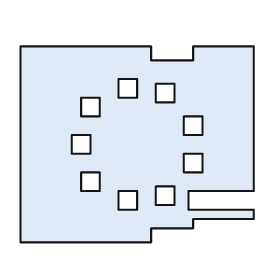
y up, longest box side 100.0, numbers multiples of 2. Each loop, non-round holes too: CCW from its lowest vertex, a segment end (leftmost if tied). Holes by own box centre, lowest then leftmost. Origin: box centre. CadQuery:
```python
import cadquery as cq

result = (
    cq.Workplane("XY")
    .moveTo(-50.0, -42.0)
    .lineTo(6.0, -42.0)
    .lineTo(6.0, -36.0)
    .lineTo(24.0, -36.0)
    .lineTo(24.0, -32.0)
    .lineTo(50.0, -32.0)
    .lineTo(50.0, -28.0)
    .lineTo(22.0, -28.0)
    .lineTo(22.0, -20.0)
    .lineTo(50.0, -20.0)
    .lineTo(50.0, 42.0)
    .lineTo(24.0, 42.0)
    .lineTo(24.0, 36.0)
    .lineTo(6.0, 36.0)
    .lineTo(6.0, 42.0)
    .lineTo(-50.0, 42.0)
    .close()
    .moveTo(-8.0, -28.0)
    .lineTo(0.0, -28.0)
    .lineTo(0.0, -20.0)
    .lineTo(-8.0, -20.0)
    .close()
    .moveTo(8.0, -26.0)
    .lineTo(16.0, -26.0)
    .lineTo(16.0, -18.0)
    .lineTo(8.0, -18.0)
    .close()
    .moveTo(-24.0, -20.0)
    .lineTo(-16.0, -20.0)
    .lineTo(-16.0, -12.0)
    .lineTo(-24.0, -12.0)
    .close()
    .moveTo(20.0, -12.0)
    .lineTo(28.0, -12.0)
    .lineTo(28.0, -4.0)
    .lineTo(20.0, -4.0)
    .close()
    .moveTo(-28.0, -4.0)
    .lineTo(-20.0, -4.0)
    .lineTo(-20.0, 4.0)
    .lineTo(-28.0, 4.0)
    .close()
    .moveTo(20.0, 4.0)
    .lineTo(28.0, 4.0)
    .lineTo(28.0, 12.0)
    .lineTo(20.0, 12.0)
    .close()
    .moveTo(-24.0, 12.0)
    .lineTo(-16.0, 12.0)
    .lineTo(-16.0, 20.0)
    .lineTo(-24.0, 20.0)
    .close()
    .moveTo(8.0, 18.0)
    .lineTo(16.0, 18.0)
    .lineTo(16.0, 26.0)
    .lineTo(8.0, 26.0)
    .close()
    .moveTo(-8.0, 20.0)
    .lineTo(0.0, 20.0)
    .lineTo(0.0, 28.0)
    .lineTo(-8.0, 28.0)
    .close()
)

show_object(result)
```